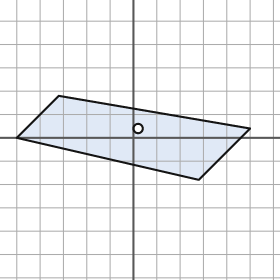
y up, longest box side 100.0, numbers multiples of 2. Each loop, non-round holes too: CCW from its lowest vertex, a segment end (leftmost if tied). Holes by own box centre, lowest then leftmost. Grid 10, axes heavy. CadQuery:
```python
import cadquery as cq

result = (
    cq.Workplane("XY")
    .moveTo(28.0, -18.0)
    .lineTo(50.0, 4.0)
    .lineTo(-32.0, 18.0)
    .lineTo(-50.0, 0.0)
    .close()
    .moveTo(2.0, 4.0)
    .circle(2.0)
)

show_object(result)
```